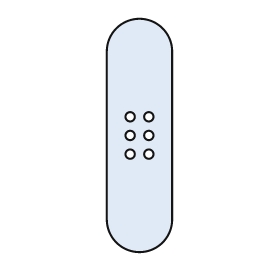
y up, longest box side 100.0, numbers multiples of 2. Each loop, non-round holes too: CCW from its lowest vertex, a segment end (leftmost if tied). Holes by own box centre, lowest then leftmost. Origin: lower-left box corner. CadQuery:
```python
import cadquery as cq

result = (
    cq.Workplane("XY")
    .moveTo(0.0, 14.0)
    .threePointArc((14.0, 0.0), (28.0, 14.0))
    .lineTo(28.0, 86.0)
    .threePointArc((14.0, 100.0), (0.0, 86.0))
    .close()
    .moveTo(10.0, 42.0)
    .circle(2.0)
    .moveTo(18.0, 42.0)
    .circle(2.0)
    .moveTo(10.0, 50.0)
    .circle(2.0)
    .moveTo(18.0, 50.0)
    .circle(2.0)
    .moveTo(10.0, 58.0)
    .circle(2.0)
    .moveTo(18.0, 58.0)
    .circle(2.0)
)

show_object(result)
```